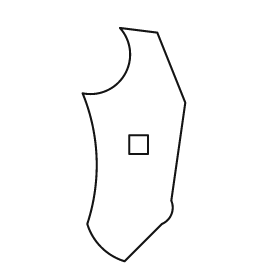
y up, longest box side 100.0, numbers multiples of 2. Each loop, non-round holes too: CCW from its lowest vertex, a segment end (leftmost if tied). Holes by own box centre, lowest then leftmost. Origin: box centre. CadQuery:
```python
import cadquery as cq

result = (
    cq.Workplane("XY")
    .moveTo(-4.0, -50.0)
    .lineTo(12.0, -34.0)
    .threePointArc((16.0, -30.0), (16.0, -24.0))
    .lineTo(22.0, 18.0)
    .lineTo(10.0, 48.0)
    .lineTo(-6.0, 50.0)
    .threePointArc((-4.0, 30.0), (-22.0, 22.0))
    .threePointArc((-16.0, -6.0), (-20.0, -34.0))
    .threePointArc((-14.0, -44.0), (-4.0, -50.0))
    .close()
    .moveTo(-2.0, -4.0)
    .lineTo(6.0, -4.0)
    .lineTo(6.0, 4.0)
    .lineTo(-2.0, 4.0)
    .close()
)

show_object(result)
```